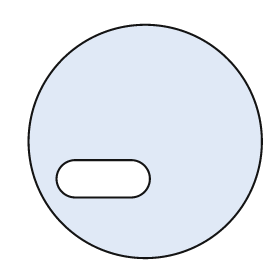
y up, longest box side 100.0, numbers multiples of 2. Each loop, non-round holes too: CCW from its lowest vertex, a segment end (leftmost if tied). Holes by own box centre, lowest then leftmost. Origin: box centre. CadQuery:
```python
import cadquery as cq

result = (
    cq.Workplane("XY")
    .moveTo(0.0, 0.0)
    .circle(50.0)
    .moveTo(-30.0, -24.0)
    .lineTo(-6.0, -24.0)
    .threePointArc((2.0, -16.0), (-6.0, -8.0))
    .lineTo(-30.0, -8.0)
    .threePointArc((-38.0, -16.0), (-30.0, -24.0))
    .close()
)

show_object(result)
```